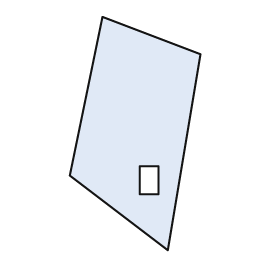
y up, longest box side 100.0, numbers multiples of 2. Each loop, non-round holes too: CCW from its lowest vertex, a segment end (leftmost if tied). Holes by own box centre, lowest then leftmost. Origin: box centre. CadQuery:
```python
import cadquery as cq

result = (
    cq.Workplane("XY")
    .moveTo(14.0, -50.0)
    .lineTo(28.0, 34.0)
    .lineTo(-14.0, 50.0)
    .lineTo(-28.0, -18.0)
    .close()
    .moveTo(2.0, -26.0)
    .lineTo(10.0, -26.0)
    .lineTo(10.0, -14.0)
    .lineTo(2.0, -14.0)
    .close()
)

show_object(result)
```